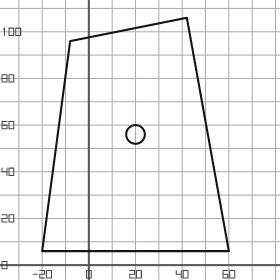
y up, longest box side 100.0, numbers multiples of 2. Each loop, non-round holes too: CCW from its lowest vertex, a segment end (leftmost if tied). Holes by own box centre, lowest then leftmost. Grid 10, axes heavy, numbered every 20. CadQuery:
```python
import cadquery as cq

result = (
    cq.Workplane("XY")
    .moveTo(-20.0, 6.0)
    .lineTo(60.0, 6.0)
    .lineTo(42.0, 106.0)
    .lineTo(-8.0, 96.0)
    .close()
    .moveTo(20.0, 56.0)
    .circle(4.0)
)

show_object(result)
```